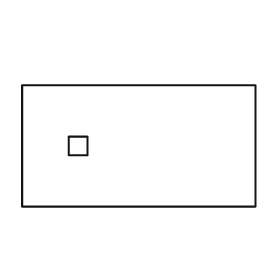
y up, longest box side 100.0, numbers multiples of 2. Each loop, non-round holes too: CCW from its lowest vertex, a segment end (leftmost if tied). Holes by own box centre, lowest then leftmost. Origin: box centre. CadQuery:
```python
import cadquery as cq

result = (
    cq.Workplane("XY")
    .moveTo(-50.0, -26.0)
    .lineTo(50.0, -26.0)
    .lineTo(50.0, 26.0)
    .lineTo(-50.0, 26.0)
    .close()
    .moveTo(-30.0, -4.0)
    .lineTo(-22.0, -4.0)
    .lineTo(-22.0, 4.0)
    .lineTo(-30.0, 4.0)
    .close()
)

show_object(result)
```